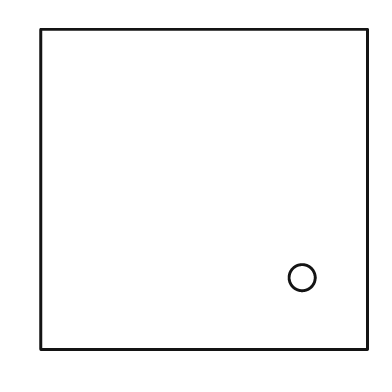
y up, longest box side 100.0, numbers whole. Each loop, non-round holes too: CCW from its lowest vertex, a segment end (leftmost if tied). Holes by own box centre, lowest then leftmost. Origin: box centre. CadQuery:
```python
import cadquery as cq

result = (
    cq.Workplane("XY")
    .moveTo(-50.0, -49.0)
    .lineTo(50.0, -49.0)
    .lineTo(50.0, 49.0)
    .lineTo(-50.0, 49.0)
    .close()
    .moveTo(30.0, -27.0)
    .circle(4.0)
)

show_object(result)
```